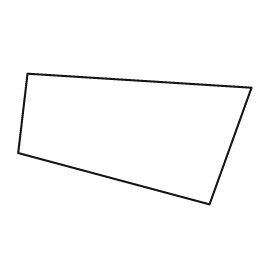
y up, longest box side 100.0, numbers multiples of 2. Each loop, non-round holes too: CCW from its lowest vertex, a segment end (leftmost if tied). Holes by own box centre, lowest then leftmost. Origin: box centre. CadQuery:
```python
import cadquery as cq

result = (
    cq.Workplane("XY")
    .moveTo(32.0, -28.0)
    .lineTo(50.0, 22.0)
    .lineTo(-46.0, 28.0)
    .lineTo(-50.0, -6.0)
    .close()
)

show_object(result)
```